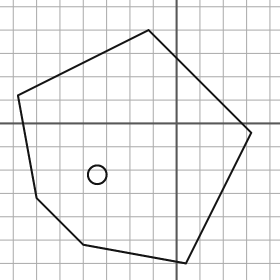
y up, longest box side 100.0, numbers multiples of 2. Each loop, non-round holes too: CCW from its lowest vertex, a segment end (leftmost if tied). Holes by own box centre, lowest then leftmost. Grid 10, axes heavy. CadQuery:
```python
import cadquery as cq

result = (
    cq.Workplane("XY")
    .moveTo(4.0, -60.0)
    .lineTo(32.0, -4.0)
    .lineTo(-12.0, 40.0)
    .lineTo(-68.0, 12.0)
    .lineTo(-60.0, -32.0)
    .lineTo(-40.0, -52.0)
    .close()
    .moveTo(-34.0, -22.0)
    .circle(4.0)
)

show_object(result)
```